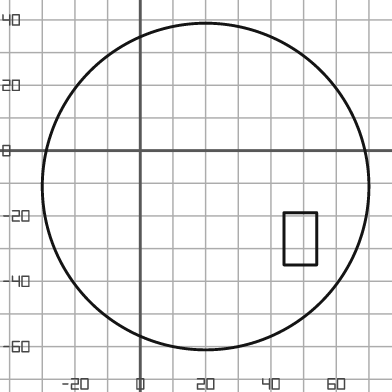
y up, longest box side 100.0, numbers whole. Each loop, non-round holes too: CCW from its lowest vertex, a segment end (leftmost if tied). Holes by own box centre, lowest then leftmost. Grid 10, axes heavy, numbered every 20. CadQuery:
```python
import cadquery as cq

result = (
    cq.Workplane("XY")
    .moveTo(20.0, -11.0)
    .circle(50.0)
    .moveTo(44.0, -35.0)
    .lineTo(54.0, -35.0)
    .lineTo(54.0, -19.0)
    .lineTo(44.0, -19.0)
    .close()
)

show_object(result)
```